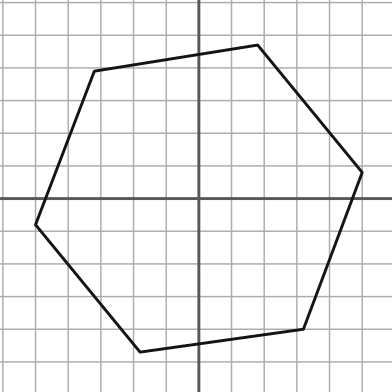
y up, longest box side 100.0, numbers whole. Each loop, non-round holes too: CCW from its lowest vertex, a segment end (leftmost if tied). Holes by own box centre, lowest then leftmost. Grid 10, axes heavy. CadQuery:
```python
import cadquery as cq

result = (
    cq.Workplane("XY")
    .moveTo(-18.0, -47.0)
    .lineTo(32.0, -40.0)
    .lineTo(50.0, 8.0)
    .lineTo(18.0, 47.0)
    .lineTo(-32.0, 39.0)
    .lineTo(-50.0, -8.0)
    .close()
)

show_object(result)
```